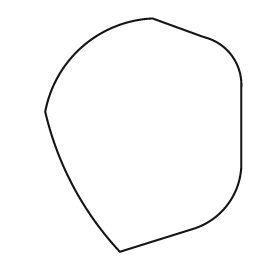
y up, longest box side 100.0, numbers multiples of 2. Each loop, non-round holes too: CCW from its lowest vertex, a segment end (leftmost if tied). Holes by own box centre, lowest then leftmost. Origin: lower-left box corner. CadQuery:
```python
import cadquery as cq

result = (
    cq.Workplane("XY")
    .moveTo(32.0, 0.0)
    .lineTo(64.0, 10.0)
    .threePointArc((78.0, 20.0), (84.0, 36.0))
    .lineTo(84.0, 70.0)
    .threePointArc((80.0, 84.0), (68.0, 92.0))
    .lineTo(46.0, 100.0)
    .threePointArc((16.0, 88.0), (0.0, 60.0))
    .threePointArc((12.0, 28.0), (32.0, 0.0))
    .close()
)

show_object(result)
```